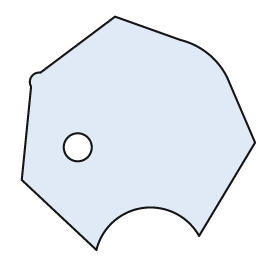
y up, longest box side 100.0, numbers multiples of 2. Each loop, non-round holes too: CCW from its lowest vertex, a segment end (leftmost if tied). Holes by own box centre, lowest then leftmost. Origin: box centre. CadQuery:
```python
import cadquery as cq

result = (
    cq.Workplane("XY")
    .moveTo(-18.0, -50.0)
    .threePointArc((2.0, -32.0), (26.0, -44.0))
    .lineTo(50.0, -4.0)
    .lineTo(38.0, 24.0)
    .threePointArc((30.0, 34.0), (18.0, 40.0))
    .lineTo(-10.0, 50.0)
    .lineTo(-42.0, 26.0)
    .threePointArc((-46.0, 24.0), (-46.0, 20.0))
    .lineTo(-50.0, -20.0)
    .close()
    .moveTo(-26.0, -6.0)
    .circle(6.0)
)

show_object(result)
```